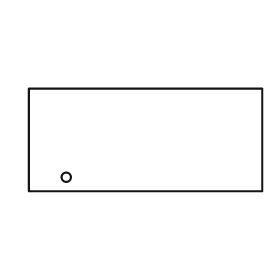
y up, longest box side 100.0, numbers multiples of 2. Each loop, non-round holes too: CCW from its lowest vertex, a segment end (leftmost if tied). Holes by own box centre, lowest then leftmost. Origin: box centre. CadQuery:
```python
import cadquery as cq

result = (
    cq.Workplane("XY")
    .moveTo(-50.0, -22.0)
    .lineTo(50.0, -22.0)
    .lineTo(50.0, 22.0)
    .lineTo(-50.0, 22.0)
    .close()
    .moveTo(-34.0, -16.0)
    .circle(2.0)
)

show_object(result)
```